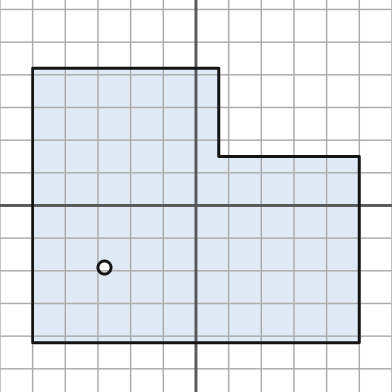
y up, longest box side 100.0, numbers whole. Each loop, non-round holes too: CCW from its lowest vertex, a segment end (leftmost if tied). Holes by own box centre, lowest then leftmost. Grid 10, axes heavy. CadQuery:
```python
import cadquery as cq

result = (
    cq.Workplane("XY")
    .moveTo(-50.0, -42.0)
    .lineTo(50.0, -42.0)
    .lineTo(50.0, 15.0)
    .lineTo(7.0, 15.0)
    .lineTo(7.0, 42.0)
    .lineTo(-50.0, 42.0)
    .close()
    .moveTo(-28.0, -19.0)
    .circle(2.0)
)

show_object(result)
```